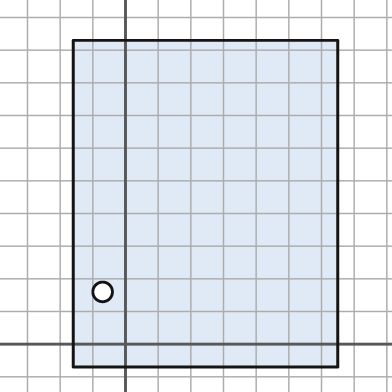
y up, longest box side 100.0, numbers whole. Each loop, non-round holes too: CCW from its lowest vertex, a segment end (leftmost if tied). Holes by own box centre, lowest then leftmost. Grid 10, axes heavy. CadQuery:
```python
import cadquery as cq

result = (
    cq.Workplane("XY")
    .moveTo(-16.0, -7.0)
    .lineTo(65.0, -7.0)
    .lineTo(65.0, 93.0)
    .lineTo(-16.0, 93.0)
    .close()
    .moveTo(-7.0, 16.0)
    .circle(3.0)
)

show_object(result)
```